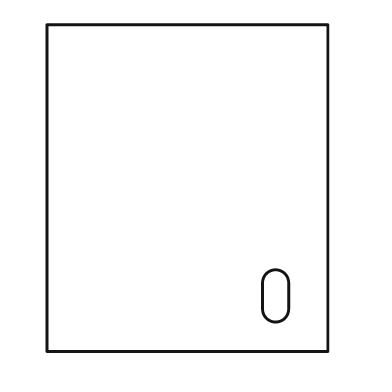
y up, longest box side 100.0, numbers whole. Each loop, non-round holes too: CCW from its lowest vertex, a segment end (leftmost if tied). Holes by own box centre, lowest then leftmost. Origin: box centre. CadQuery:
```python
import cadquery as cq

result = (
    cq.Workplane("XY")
    .moveTo(-43.0, -50.0)
    .lineTo(43.0, -50.0)
    .lineTo(43.0, 50.0)
    .lineTo(-43.0, 50.0)
    .close()
    .moveTo(23.0, -37.0)
    .threePointArc((27.0, -41.0), (31.0, -37.0))
    .lineTo(31.0, -29.0)
    .threePointArc((27.0, -25.0), (23.0, -29.0))
    .close()
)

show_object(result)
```